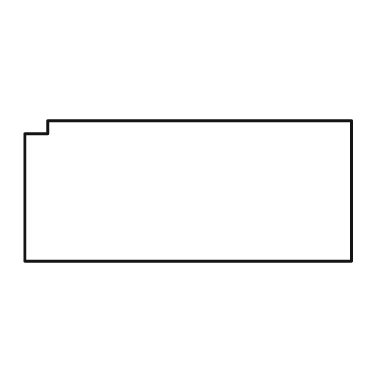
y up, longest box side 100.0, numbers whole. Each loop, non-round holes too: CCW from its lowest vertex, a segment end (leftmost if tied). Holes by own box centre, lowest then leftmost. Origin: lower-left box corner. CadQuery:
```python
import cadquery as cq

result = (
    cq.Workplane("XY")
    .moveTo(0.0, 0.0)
    .lineTo(100.0, 0.0)
    .lineTo(100.0, 43.0)
    .lineTo(7.0, 43.0)
    .lineTo(7.0, 39.0)
    .lineTo(0.0, 39.0)
    .close()
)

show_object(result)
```